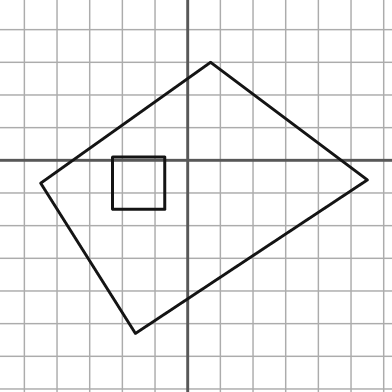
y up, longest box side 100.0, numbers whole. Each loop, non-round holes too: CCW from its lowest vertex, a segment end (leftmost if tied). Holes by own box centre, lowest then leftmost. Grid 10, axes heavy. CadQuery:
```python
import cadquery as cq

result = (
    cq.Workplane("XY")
    .moveTo(-16.0, -53.0)
    .lineTo(55.0, -6.0)
    .lineTo(7.0, 30.0)
    .lineTo(-45.0, -7.0)
    .close()
    .moveTo(-23.0, -15.0)
    .lineTo(-7.0, -15.0)
    .lineTo(-7.0, 1.0)
    .lineTo(-23.0, 1.0)
    .close()
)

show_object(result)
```